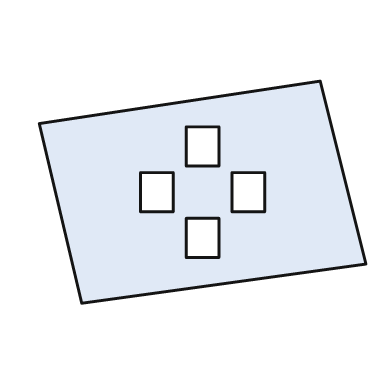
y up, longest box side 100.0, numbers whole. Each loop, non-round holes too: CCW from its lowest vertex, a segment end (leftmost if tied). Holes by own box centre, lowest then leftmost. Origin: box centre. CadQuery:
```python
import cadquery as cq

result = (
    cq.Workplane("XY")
    .moveTo(-37.0, -34.0)
    .lineTo(50.0, -22.0)
    .lineTo(36.0, 34.0)
    .lineTo(-50.0, 21.0)
    .close()
    .moveTo(-5.0, -20.0)
    .lineTo(5.0, -20.0)
    .lineTo(5.0, -8.0)
    .lineTo(-5.0, -8.0)
    .close()
    .moveTo(-19.0, -6.0)
    .lineTo(-9.0, -6.0)
    .lineTo(-9.0, 6.0)
    .lineTo(-19.0, 6.0)
    .close()
    .moveTo(9.0, -6.0)
    .lineTo(19.0, -6.0)
    .lineTo(19.0, 6.0)
    .lineTo(9.0, 6.0)
    .close()
    .moveTo(-5.0, 8.0)
    .lineTo(5.0, 8.0)
    .lineTo(5.0, 20.0)
    .lineTo(-5.0, 20.0)
    .close()
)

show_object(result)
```